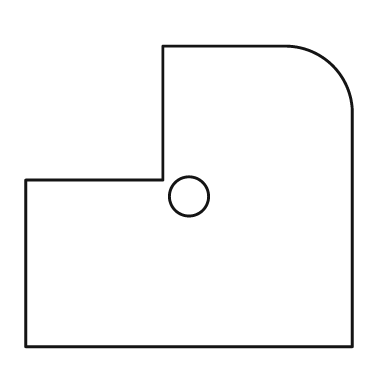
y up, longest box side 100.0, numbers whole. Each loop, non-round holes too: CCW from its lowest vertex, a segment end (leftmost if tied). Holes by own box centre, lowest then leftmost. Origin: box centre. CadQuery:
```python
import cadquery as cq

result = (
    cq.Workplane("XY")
    .moveTo(-50.0, -46.0)
    .lineTo(50.0, -46.0)
    .lineTo(50.0, 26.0)
    .threePointArc((44.0, 40.0), (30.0, 46.0))
    .lineTo(-8.0, 46.0)
    .lineTo(-8.0, 5.0)
    .lineTo(-50.0, 5.0)
    .close()
    .moveTo(0.0, 0.0)
    .circle(6.0)
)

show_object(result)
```